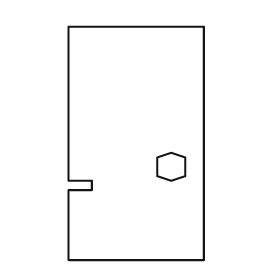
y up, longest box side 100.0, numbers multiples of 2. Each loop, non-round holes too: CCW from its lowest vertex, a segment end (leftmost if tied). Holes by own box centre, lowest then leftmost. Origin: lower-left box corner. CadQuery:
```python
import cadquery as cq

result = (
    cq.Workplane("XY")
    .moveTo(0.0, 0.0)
    .lineTo(58.0, 0.0)
    .lineTo(58.0, 100.0)
    .lineTo(0.0, 100.0)
    .lineTo(0.0, 34.0)
    .lineTo(10.0, 34.0)
    .lineTo(10.0, 30.0)
    .lineTo(0.0, 30.0)
    .close()
    .moveTo(44.0, 34.0)
    .lineTo(50.0, 36.0)
    .lineTo(50.0, 44.0)
    .lineTo(44.0, 46.0)
    .lineTo(38.0, 44.0)
    .lineTo(38.0, 36.0)
    .close()
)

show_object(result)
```